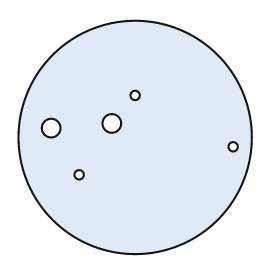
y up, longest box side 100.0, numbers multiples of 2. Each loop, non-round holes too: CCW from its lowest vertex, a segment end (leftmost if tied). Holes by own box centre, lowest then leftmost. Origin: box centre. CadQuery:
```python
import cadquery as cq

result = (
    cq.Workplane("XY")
    .moveTo(0.0, 0.0)
    .circle(50.0)
    .moveTo(-24.0, -16.0)
    .circle(2.0)
    .moveTo(42.0, -4.0)
    .circle(2.0)
    .moveTo(-36.0, 4.0)
    .circle(4.0)
    .moveTo(-10.0, 6.0)
    .circle(4.0)
    .moveTo(0.0, 18.0)
    .circle(2.0)
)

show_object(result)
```